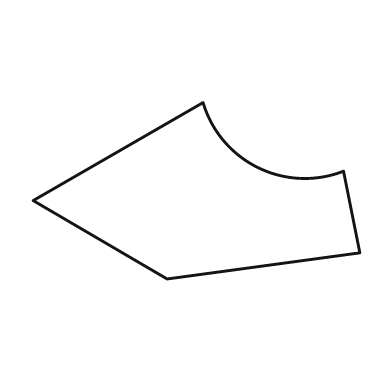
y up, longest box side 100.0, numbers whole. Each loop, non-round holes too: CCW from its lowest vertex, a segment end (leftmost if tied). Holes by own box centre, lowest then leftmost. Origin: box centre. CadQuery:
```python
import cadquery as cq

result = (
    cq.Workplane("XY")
    .moveTo(-9.0, -27.0)
    .lineTo(50.0, -19.0)
    .lineTo(45.0, 6.0)
    .threePointArc((19.0, 7.0), (2.0, 27.0))
    .lineTo(-50.0, -3.0)
    .close()
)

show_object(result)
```